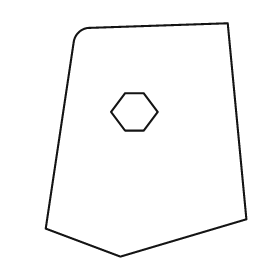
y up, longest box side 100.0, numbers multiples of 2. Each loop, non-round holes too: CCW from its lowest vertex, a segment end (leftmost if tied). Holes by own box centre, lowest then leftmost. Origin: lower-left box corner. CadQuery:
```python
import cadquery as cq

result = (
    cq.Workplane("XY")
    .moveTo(32.0, 0.0)
    .lineTo(86.0, 16.0)
    .lineTo(78.0, 100.0)
    .lineTo(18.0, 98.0)
    .threePointArc((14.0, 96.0), (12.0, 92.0))
    .lineTo(0.0, 12.0)
    .close()
    .moveTo(34.0, 54.0)
    .lineTo(42.0, 54.0)
    .lineTo(48.0, 62.0)
    .lineTo(42.0, 70.0)
    .lineTo(34.0, 70.0)
    .lineTo(28.0, 62.0)
    .close()
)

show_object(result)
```